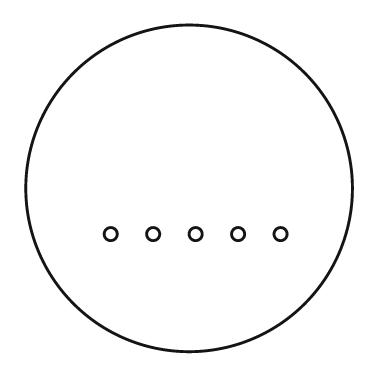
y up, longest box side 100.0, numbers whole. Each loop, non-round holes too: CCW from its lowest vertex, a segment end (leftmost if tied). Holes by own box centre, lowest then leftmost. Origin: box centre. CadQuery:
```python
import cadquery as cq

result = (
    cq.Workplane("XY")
    .moveTo(0.0, 0.0)
    .circle(50.0)
    .moveTo(-24.0, -14.0)
    .circle(2.0)
    .moveTo(-11.0, -14.0)
    .circle(2.0)
    .moveTo(2.0, -14.0)
    .circle(2.0)
    .moveTo(15.0, -14.0)
    .circle(2.0)
    .moveTo(28.0, -14.0)
    .circle(2.0)
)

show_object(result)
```